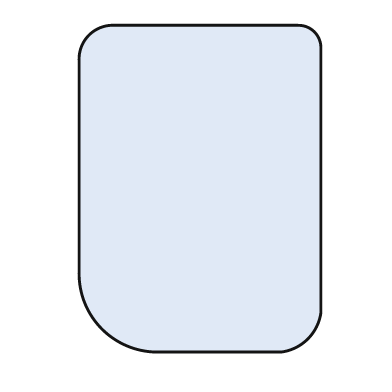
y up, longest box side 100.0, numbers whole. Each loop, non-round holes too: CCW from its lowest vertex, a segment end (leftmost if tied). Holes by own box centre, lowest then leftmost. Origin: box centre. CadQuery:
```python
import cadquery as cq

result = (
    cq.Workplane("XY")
    .moveTo(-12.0, -50.0)
    .lineTo(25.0, -50.0)
    .threePointArc((33.0, -46.0), (37.0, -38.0))
    .lineTo(37.0, 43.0)
    .threePointArc((35.0, 48.0), (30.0, 50.0))
    .lineTo(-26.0, 50.0)
    .threePointArc((-34.0, 47.0), (-37.0, 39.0))
    .lineTo(-37.0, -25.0)
    .threePointArc((-30.0, -43.0), (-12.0, -50.0))
    .close()
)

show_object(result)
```